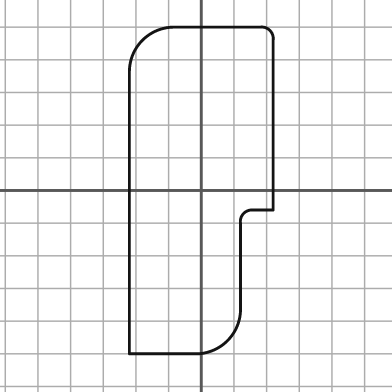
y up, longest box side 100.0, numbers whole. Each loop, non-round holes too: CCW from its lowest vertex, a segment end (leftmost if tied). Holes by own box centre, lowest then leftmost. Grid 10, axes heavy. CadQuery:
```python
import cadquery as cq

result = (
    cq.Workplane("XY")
    .moveTo(-22.0, -50.0)
    .lineTo(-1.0, -50.0)
    .threePointArc((8.0, -46.0), (12.0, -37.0))
    .lineTo(12.0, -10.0)
    .threePointArc((13.0, -7.0), (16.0, -6.0))
    .lineTo(22.0, -6.0)
    .lineTo(22.0, 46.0)
    .threePointArc((21.0, 49.0), (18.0, 50.0))
    .lineTo(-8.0, 50.0)
    .threePointArc((-18.0, 46.0), (-22.0, 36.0))
    .close()
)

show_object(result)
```